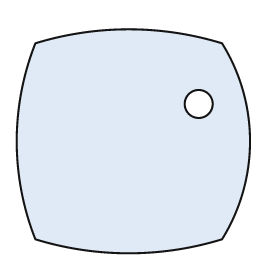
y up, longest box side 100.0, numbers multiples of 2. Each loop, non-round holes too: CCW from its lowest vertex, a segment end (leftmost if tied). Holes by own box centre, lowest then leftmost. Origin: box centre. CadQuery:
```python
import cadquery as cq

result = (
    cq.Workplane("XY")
    .moveTo(-42.0, -42.0)
    .threePointArc((-2.0, -48.0), (38.0, -42.0))
    .threePointArc((50.0, 0.0), (38.0, 42.0))
    .threePointArc((-2.0, 48.0), (-42.0, 42.0))
    .threePointArc((-50.0, 0.0), (-42.0, -42.0))
    .close()
    .moveTo(28.0, 16.0)
    .circle(6.0)
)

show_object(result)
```